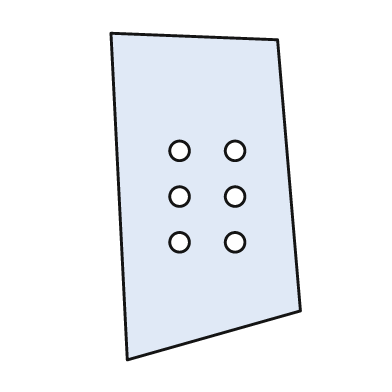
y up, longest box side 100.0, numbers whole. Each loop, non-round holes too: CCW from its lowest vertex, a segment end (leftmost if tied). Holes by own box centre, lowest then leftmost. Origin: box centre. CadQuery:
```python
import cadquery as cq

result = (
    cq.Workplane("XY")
    .moveTo(-24.0, -50.0)
    .lineTo(29.0, -35.0)
    .lineTo(22.0, 48.0)
    .lineTo(-29.0, 50.0)
    .close()
    .moveTo(-8.0, -14.0)
    .circle(3.0)
    .moveTo(9.0, -14.0)
    .circle(3.0)
    .moveTo(-8.0, 0.0)
    .circle(3.0)
    .moveTo(9.0, 0.0)
    .circle(3.0)
    .moveTo(-8.0, 14.0)
    .circle(3.0)
    .moveTo(9.0, 14.0)
    .circle(3.0)
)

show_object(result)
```